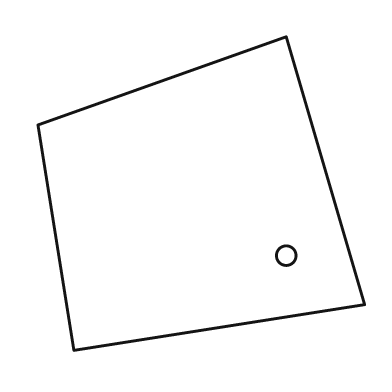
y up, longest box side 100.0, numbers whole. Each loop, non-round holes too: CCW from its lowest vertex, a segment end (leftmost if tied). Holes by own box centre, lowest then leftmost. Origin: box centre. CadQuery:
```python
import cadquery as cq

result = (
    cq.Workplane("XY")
    .moveTo(-39.0, -48.0)
    .lineTo(50.0, -34.0)
    .lineTo(26.0, 48.0)
    .lineTo(-50.0, 21.0)
    .close()
    .moveTo(26.0, -19.0)
    .circle(3.0)
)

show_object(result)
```